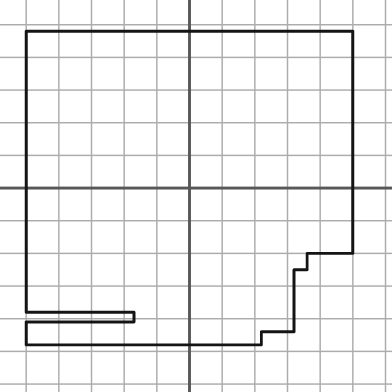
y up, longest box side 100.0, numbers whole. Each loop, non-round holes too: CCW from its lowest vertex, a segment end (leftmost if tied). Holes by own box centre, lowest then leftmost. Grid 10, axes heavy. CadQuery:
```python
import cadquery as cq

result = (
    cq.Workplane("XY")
    .moveTo(-50.0, -48.0)
    .lineTo(22.0, -48.0)
    .lineTo(22.0, -44.0)
    .lineTo(32.0, -44.0)
    .lineTo(32.0, -25.0)
    .lineTo(36.0, -25.0)
    .lineTo(36.0, -20.0)
    .lineTo(50.0, -20.0)
    .lineTo(50.0, 48.0)
    .lineTo(-50.0, 48.0)
    .lineTo(-50.0, -38.0)
    .lineTo(-17.0, -38.0)
    .lineTo(-17.0, -41.0)
    .lineTo(-50.0, -41.0)
    .close()
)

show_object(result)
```